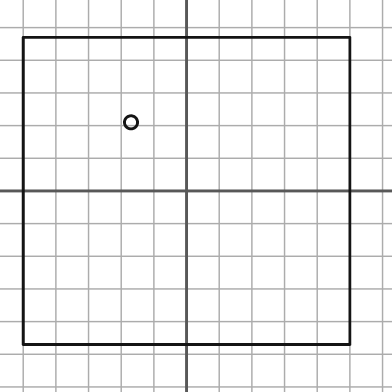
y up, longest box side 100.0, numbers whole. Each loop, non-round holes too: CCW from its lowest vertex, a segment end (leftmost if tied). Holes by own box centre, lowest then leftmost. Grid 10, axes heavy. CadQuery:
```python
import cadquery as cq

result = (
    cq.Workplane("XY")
    .moveTo(-50.0, -47.0)
    .lineTo(50.0, -47.0)
    .lineTo(50.0, 47.0)
    .lineTo(-50.0, 47.0)
    .close()
    .moveTo(-17.0, 21.0)
    .circle(2.0)
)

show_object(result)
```